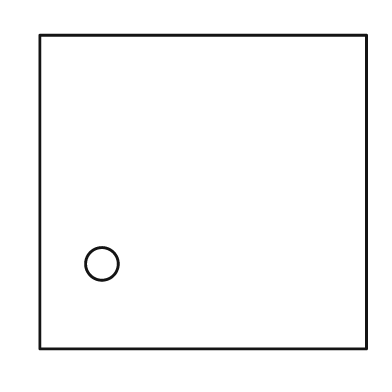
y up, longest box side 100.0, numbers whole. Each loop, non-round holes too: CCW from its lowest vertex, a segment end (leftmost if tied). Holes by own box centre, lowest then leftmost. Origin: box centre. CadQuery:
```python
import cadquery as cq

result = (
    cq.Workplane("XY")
    .moveTo(-50.0, -48.0)
    .lineTo(50.0, -48.0)
    .lineTo(50.0, 48.0)
    .lineTo(-50.0, 48.0)
    .close()
    .moveTo(-31.0, -22.0)
    .circle(5.0)
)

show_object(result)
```